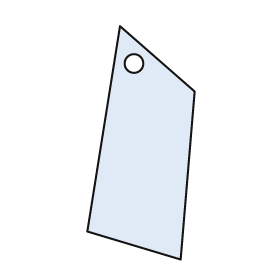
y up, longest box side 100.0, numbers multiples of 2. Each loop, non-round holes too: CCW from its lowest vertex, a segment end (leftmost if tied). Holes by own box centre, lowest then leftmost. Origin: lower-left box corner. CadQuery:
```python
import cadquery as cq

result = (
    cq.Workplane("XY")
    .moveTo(40.0, 0.0)
    .lineTo(46.0, 72.0)
    .lineTo(14.0, 100.0)
    .lineTo(0.0, 12.0)
    .close()
    .moveTo(20.0, 84.0)
    .circle(4.0)
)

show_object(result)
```